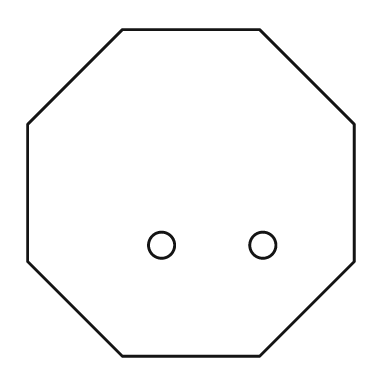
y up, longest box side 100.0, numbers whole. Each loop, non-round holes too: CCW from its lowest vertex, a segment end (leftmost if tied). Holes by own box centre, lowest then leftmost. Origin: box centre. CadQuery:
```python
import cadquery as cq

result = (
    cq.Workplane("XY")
    .moveTo(-21.0, -50.0)
    .lineTo(21.0, -50.0)
    .lineTo(50.0, -21.0)
    .lineTo(50.0, 21.0)
    .lineTo(21.0, 50.0)
    .lineTo(-21.0, 50.0)
    .lineTo(-50.0, 21.0)
    .lineTo(-50.0, -21.0)
    .close()
    .moveTo(-9.0, -16.0)
    .circle(4.0)
    .moveTo(22.0, -16.0)
    .circle(4.0)
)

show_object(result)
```